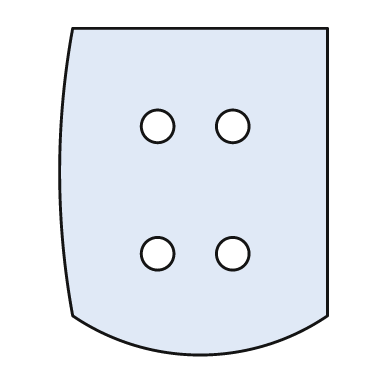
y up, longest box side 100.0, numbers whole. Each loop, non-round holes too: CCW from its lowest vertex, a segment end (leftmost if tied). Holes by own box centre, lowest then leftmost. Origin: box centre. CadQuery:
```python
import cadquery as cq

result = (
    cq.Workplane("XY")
    .moveTo(-37.0, -38.0)
    .threePointArc((2.0, -50.0), (41.0, -38.0))
    .lineTo(41.0, 50.0)
    .lineTo(-37.0, 50.0)
    .threePointArc((-41.0, 6.0), (-37.0, -38.0))
    .close()
    .moveTo(-11.0, -19.0)
    .circle(5.0)
    .moveTo(12.0, -19.0)
    .circle(5.0)
    .moveTo(-11.0, 20.0)
    .circle(5.0)
    .moveTo(12.0, 20.0)
    .circle(5.0)
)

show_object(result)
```